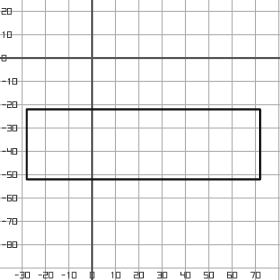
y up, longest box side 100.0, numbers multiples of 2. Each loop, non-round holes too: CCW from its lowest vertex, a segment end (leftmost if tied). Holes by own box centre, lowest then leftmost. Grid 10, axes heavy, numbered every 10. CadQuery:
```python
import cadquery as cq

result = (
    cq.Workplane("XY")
    .moveTo(-28.0, -52.0)
    .lineTo(72.0, -52.0)
    .lineTo(72.0, -22.0)
    .lineTo(-28.0, -22.0)
    .close()
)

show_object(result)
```